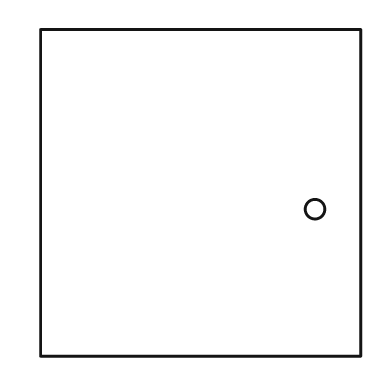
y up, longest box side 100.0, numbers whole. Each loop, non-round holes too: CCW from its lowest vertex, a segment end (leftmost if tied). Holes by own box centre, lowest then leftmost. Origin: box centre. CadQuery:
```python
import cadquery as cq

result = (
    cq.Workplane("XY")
    .moveTo(-49.0, -50.0)
    .lineTo(49.0, -50.0)
    .lineTo(49.0, 50.0)
    .lineTo(-49.0, 50.0)
    .close()
    .moveTo(35.0, -5.0)
    .circle(3.0)
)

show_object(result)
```